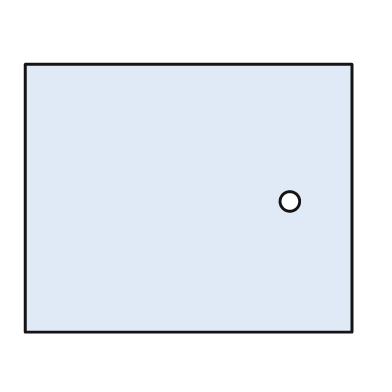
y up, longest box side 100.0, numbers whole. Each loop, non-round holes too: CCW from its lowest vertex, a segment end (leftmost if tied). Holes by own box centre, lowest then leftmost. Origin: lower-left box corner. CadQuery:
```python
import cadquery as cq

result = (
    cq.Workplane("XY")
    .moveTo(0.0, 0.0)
    .lineTo(100.0, 0.0)
    .lineTo(100.0, 82.0)
    .lineTo(0.0, 82.0)
    .close()
    .moveTo(81.0, 40.0)
    .circle(3.0)
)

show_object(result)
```